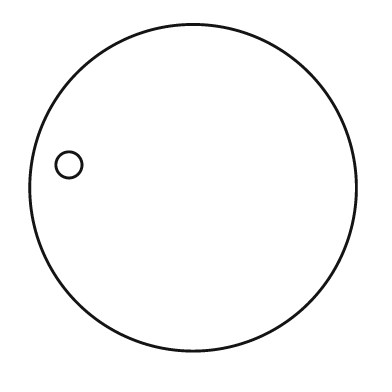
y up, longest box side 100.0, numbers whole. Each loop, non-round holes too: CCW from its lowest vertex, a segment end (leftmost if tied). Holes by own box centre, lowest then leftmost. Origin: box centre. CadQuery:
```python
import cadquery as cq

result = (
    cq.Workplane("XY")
    .moveTo(0.0, 0.0)
    .circle(50.0)
    .moveTo(-38.0, 7.0)
    .circle(4.0)
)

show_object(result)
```